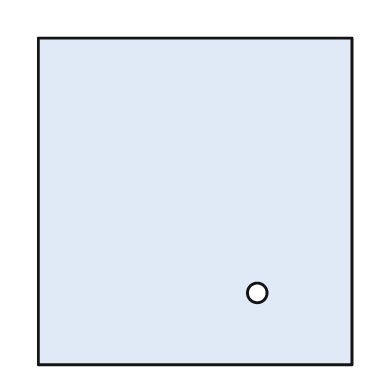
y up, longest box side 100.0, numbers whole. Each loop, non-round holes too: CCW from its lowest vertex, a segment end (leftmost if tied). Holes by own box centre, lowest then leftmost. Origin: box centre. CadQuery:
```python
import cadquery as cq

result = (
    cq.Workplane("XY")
    .moveTo(-48.0, -50.0)
    .lineTo(48.0, -50.0)
    .lineTo(48.0, 50.0)
    .lineTo(-48.0, 50.0)
    .close()
    .moveTo(19.0, -28.0)
    .circle(3.0)
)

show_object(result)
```